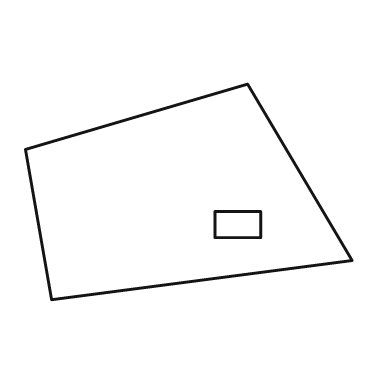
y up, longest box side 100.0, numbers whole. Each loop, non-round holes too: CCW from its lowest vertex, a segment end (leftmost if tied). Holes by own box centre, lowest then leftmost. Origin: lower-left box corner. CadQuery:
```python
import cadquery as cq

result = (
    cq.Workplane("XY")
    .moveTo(8.0, 0.0)
    .lineTo(100.0, 12.0)
    .lineTo(68.0, 66.0)
    .lineTo(0.0, 46.0)
    .close()
    .moveTo(58.0, 19.0)
    .lineTo(72.0, 19.0)
    .lineTo(72.0, 27.0)
    .lineTo(58.0, 27.0)
    .close()
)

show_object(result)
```